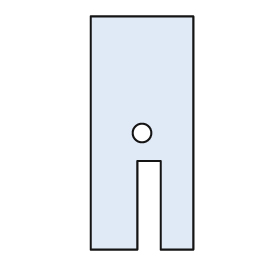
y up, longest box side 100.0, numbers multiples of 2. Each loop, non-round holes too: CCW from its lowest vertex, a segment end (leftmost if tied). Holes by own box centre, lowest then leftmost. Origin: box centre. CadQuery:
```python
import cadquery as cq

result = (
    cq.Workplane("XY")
    .moveTo(-22.0, -50.0)
    .lineTo(-2.0, -50.0)
    .lineTo(-2.0, -12.0)
    .lineTo(8.0, -12.0)
    .lineTo(8.0, -50.0)
    .lineTo(22.0, -50.0)
    .lineTo(22.0, 50.0)
    .lineTo(-22.0, 50.0)
    .close()
    .moveTo(0.0, 0.0)
    .circle(4.0)
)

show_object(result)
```